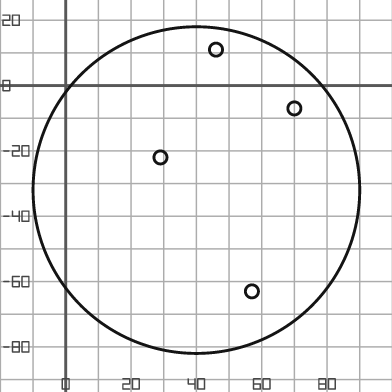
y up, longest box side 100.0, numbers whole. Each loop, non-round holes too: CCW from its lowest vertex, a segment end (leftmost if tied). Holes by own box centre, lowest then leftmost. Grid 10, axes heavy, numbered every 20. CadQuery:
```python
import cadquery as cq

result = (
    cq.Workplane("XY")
    .moveTo(40.0, -32.0)
    .circle(50.0)
    .moveTo(57.0, -63.0)
    .circle(2.0)
    .moveTo(29.0, -22.0)
    .circle(2.0)
    .moveTo(70.0, -7.0)
    .circle(2.0)
    .moveTo(46.0, 11.0)
    .circle(2.0)
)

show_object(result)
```